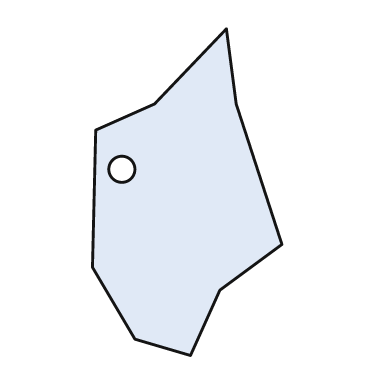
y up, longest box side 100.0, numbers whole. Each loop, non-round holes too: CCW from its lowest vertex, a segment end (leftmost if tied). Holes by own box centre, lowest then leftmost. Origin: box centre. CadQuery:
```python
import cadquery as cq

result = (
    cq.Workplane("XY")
    .moveTo(1.0, -50.0)
    .lineTo(10.0, -30.0)
    .lineTo(29.0, -16.0)
    .lineTo(15.0, 27.0)
    .lineTo(12.0, 50.0)
    .lineTo(-10.0, 27.0)
    .lineTo(-28.0, 19.0)
    .lineTo(-29.0, -23.0)
    .lineTo(-16.0, -45.0)
    .close()
    .moveTo(-20.0, 7.0)
    .circle(4.0)
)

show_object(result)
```